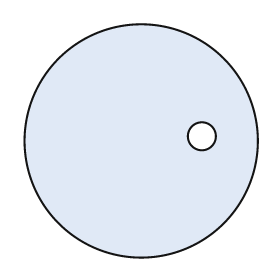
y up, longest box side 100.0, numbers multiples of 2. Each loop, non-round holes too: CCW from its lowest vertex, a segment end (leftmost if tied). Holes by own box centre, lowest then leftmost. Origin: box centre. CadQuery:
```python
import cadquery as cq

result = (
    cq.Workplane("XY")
    .moveTo(0.0, 0.0)
    .circle(50.0)
    .moveTo(26.0, 2.0)
    .circle(6.0)
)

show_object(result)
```